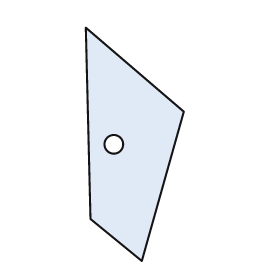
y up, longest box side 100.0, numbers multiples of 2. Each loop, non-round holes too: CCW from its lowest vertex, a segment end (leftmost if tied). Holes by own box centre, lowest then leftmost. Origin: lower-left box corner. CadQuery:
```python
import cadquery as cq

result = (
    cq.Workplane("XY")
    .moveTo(24.0, 0.0)
    .lineTo(42.0, 64.0)
    .lineTo(0.0, 100.0)
    .lineTo(2.0, 18.0)
    .close()
    .moveTo(12.0, 50.0)
    .circle(4.0)
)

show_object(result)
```